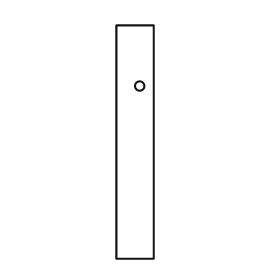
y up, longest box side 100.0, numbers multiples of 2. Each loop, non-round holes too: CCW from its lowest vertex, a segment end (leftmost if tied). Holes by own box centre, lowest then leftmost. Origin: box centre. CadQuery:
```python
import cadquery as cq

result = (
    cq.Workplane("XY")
    .moveTo(-8.0, -50.0)
    .lineTo(8.0, -50.0)
    .lineTo(8.0, 50.0)
    .lineTo(-8.0, 50.0)
    .close()
    .moveTo(2.0, 24.0)
    .circle(2.0)
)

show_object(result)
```